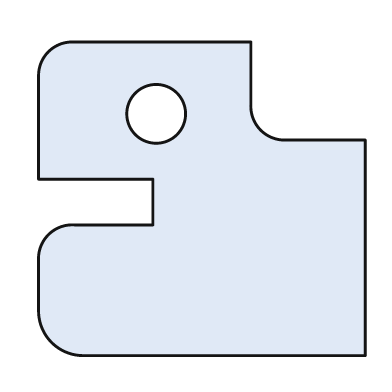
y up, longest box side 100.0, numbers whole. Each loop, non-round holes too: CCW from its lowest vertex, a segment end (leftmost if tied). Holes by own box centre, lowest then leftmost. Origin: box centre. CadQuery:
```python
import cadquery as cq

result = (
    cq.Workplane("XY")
    .moveTo(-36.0, -48.0)
    .lineTo(50.0, -48.0)
    .lineTo(50.0, 18.0)
    .lineTo(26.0, 18.0)
    .threePointArc((18.0, 21.0), (15.0, 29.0))
    .lineTo(15.0, 48.0)
    .lineTo(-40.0, 48.0)
    .threePointArc((-47.0, 45.0), (-50.0, 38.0))
    .lineTo(-50.0, 6.0)
    .lineTo(-15.0, 6.0)
    .lineTo(-15.0, -8.0)
    .lineTo(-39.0, -8.0)
    .threePointArc((-47.0, -11.0), (-50.0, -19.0))
    .lineTo(-50.0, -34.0)
    .threePointArc((-46.0, -44.0), (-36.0, -48.0))
    .close()
    .moveTo(-14.0, 26.0)
    .circle(9.0)
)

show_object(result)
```